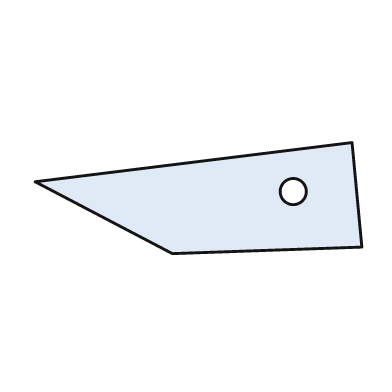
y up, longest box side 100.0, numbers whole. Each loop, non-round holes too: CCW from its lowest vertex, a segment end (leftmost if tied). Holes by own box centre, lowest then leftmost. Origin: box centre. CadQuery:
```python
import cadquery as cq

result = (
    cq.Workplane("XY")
    .moveTo(-8.0, -17.0)
    .lineTo(50.0, -15.0)
    .lineTo(47.0, 17.0)
    .lineTo(-50.0, 5.0)
    .close()
    .moveTo(29.0, 2.0)
    .circle(4.0)
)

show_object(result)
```